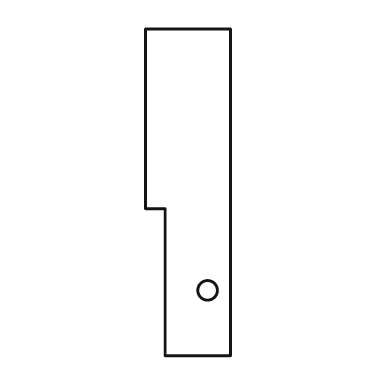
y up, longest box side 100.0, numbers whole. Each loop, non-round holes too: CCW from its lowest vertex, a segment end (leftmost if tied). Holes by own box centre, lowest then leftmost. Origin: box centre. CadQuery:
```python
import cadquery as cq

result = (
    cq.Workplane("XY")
    .moveTo(-7.0, -50.0)
    .lineTo(13.0, -50.0)
    .lineTo(13.0, 50.0)
    .lineTo(-13.0, 50.0)
    .lineTo(-13.0, -5.0)
    .lineTo(-7.0, -5.0)
    .close()
    .moveTo(6.0, -30.0)
    .circle(3.0)
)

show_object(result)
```